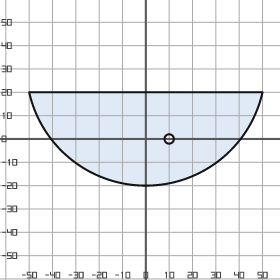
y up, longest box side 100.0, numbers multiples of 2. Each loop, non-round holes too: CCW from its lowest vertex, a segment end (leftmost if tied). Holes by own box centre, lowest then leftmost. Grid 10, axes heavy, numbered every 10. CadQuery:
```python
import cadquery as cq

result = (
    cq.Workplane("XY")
    .moveTo(-50.0, 20.0)
    .threePointArc((0.0, -20.0), (50.0, 20.0))
    .close()
    .moveTo(10.0, 0.0)
    .circle(2.0)
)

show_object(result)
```